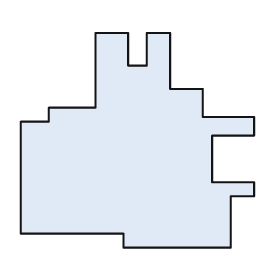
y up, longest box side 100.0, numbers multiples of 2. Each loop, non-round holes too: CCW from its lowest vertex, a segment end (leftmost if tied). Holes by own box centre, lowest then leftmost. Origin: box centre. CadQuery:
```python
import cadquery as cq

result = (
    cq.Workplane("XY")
    .moveTo(-6.0, -46.0)
    .lineTo(40.0, -46.0)
    .lineTo(40.0, -24.0)
    .lineTo(50.0, -24.0)
    .lineTo(50.0, -18.0)
    .lineTo(32.0, -18.0)
    .lineTo(32.0, 2.0)
    .lineTo(50.0, 2.0)
    .lineTo(50.0, 10.0)
    .lineTo(28.0, 10.0)
    .lineTo(28.0, 22.0)
    .lineTo(14.0, 22.0)
    .lineTo(14.0, 46.0)
    .lineTo(4.0, 46.0)
    .lineTo(4.0, 32.0)
    .lineTo(-4.0, 32.0)
    .lineTo(-4.0, 46.0)
    .lineTo(-18.0, 46.0)
    .lineTo(-18.0, 14.0)
    .lineTo(-38.0, 14.0)
    .lineTo(-38.0, 8.0)
    .lineTo(-50.0, 8.0)
    .lineTo(-50.0, -40.0)
    .lineTo(-6.0, -40.0)
    .close()
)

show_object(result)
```